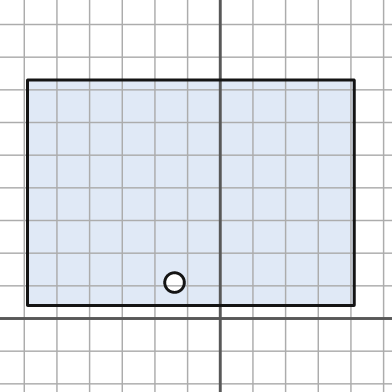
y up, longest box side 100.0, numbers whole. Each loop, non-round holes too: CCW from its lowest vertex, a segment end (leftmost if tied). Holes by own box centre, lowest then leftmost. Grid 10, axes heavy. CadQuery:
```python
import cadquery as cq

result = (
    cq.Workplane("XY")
    .moveTo(-59.0, 4.0)
    .lineTo(41.0, 4.0)
    .lineTo(41.0, 73.0)
    .lineTo(-59.0, 73.0)
    .close()
    .moveTo(-14.0, 11.0)
    .circle(3.0)
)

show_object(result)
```